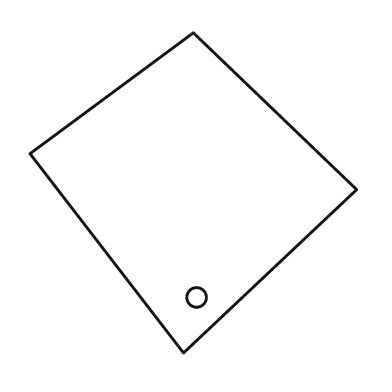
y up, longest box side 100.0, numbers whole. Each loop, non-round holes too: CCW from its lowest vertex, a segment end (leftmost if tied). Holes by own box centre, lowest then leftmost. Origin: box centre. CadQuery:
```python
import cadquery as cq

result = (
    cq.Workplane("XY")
    .moveTo(-3.0, -49.0)
    .lineTo(50.0, 1.0)
    .lineTo(0.0, 49.0)
    .lineTo(-50.0, 12.0)
    .close()
    .moveTo(1.0, -32.0)
    .circle(3.0)
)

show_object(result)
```